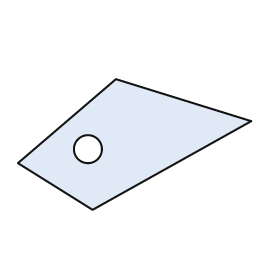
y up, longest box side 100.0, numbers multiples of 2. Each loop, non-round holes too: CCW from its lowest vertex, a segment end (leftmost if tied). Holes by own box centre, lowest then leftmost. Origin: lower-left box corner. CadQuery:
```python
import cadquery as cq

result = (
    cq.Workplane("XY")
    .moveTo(32.0, 0.0)
    .lineTo(100.0, 38.0)
    .lineTo(42.0, 56.0)
    .lineTo(0.0, 20.0)
    .close()
    .moveTo(30.0, 26.0)
    .circle(6.0)
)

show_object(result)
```